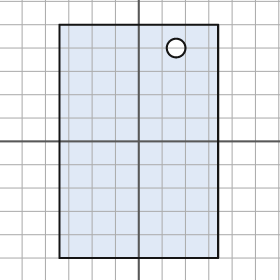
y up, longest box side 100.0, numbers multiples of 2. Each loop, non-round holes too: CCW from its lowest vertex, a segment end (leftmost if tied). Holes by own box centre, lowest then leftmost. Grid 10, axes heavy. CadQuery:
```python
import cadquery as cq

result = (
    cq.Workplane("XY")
    .moveTo(-34.0, -50.0)
    .lineTo(34.0, -50.0)
    .lineTo(34.0, 50.0)
    .lineTo(-34.0, 50.0)
    .close()
    .moveTo(16.0, 40.0)
    .circle(4.0)
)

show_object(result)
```